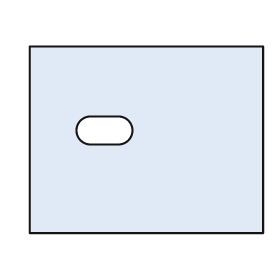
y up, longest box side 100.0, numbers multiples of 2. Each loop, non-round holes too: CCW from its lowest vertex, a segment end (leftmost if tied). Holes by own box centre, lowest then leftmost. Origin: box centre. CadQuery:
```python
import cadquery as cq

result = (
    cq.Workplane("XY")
    .moveTo(-50.0, -40.0)
    .lineTo(50.0, -40.0)
    .lineTo(50.0, 40.0)
    .lineTo(-50.0, 40.0)
    .close()
    .moveTo(-24.0, -2.0)
    .lineTo(-12.0, -2.0)
    .threePointArc((-6.0, 4.0), (-12.0, 10.0))
    .lineTo(-24.0, 10.0)
    .threePointArc((-30.0, 4.0), (-24.0, -2.0))
    .close()
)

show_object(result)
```